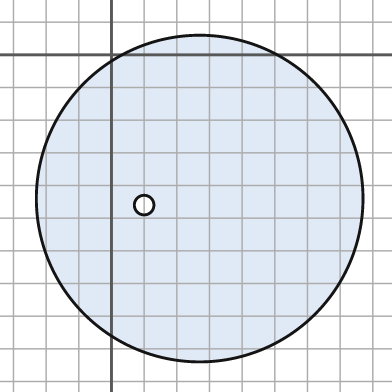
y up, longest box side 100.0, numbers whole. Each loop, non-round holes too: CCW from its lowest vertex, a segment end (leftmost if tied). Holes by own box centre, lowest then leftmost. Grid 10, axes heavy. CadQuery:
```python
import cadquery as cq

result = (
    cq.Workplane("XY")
    .moveTo(27.0, -44.0)
    .circle(50.0)
    .moveTo(10.0, -46.0)
    .circle(3.0)
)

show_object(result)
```